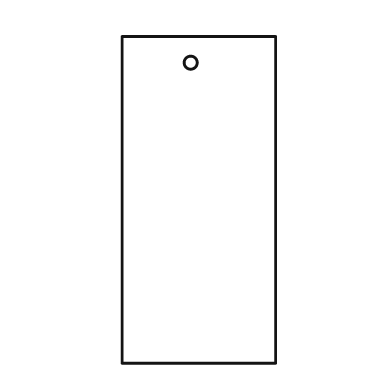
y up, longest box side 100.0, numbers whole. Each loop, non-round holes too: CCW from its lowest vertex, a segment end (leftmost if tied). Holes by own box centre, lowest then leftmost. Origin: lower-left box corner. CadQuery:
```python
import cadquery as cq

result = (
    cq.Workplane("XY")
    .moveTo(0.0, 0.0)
    .lineTo(47.0, 0.0)
    .lineTo(47.0, 100.0)
    .lineTo(0.0, 100.0)
    .close()
    .moveTo(21.0, 92.0)
    .circle(2.0)
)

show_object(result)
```